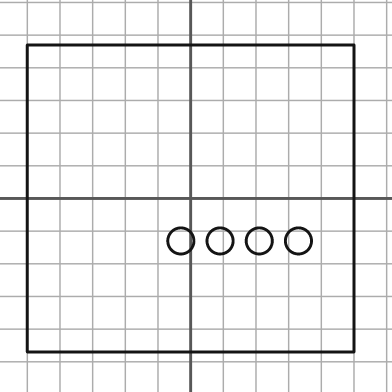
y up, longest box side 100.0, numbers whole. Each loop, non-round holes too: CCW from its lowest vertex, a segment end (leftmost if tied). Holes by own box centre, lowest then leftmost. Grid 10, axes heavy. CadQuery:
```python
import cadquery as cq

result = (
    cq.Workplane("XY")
    .moveTo(-50.0, -47.0)
    .lineTo(50.0, -47.0)
    .lineTo(50.0, 47.0)
    .lineTo(-50.0, 47.0)
    .close()
    .moveTo(-3.0, -13.0)
    .circle(4.0)
    .moveTo(9.0, -13.0)
    .circle(4.0)
    .moveTo(21.0, -13.0)
    .circle(4.0)
    .moveTo(33.0, -13.0)
    .circle(4.0)
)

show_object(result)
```